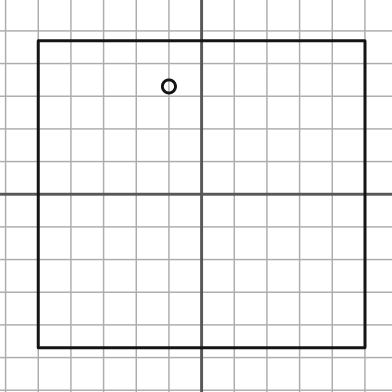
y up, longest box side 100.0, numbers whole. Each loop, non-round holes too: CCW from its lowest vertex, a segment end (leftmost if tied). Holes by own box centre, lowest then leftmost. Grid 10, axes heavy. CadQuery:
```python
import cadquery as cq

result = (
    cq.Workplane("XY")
    .moveTo(-50.0, -47.0)
    .lineTo(50.0, -47.0)
    .lineTo(50.0, 47.0)
    .lineTo(-50.0, 47.0)
    .close()
    .moveTo(-10.0, 33.0)
    .circle(2.0)
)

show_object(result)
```